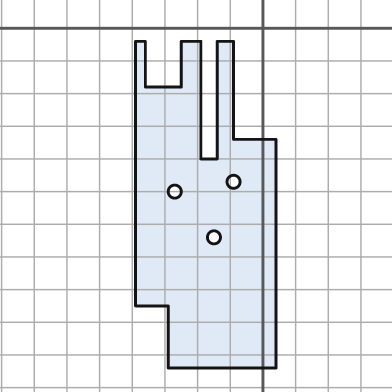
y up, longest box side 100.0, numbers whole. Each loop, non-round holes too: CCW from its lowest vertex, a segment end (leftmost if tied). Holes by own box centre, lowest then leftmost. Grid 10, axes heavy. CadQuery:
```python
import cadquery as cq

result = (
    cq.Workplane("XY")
    .moveTo(-29.0, -104.0)
    .lineTo(4.0, -104.0)
    .lineTo(4.0, -34.0)
    .lineTo(-9.0, -34.0)
    .lineTo(-9.0, -4.0)
    .lineTo(-14.0, -4.0)
    .lineTo(-14.0, -40.0)
    .lineTo(-19.0, -40.0)
    .lineTo(-19.0, -4.0)
    .lineTo(-25.0, -4.0)
    .lineTo(-25.0, -18.0)
    .lineTo(-36.0, -18.0)
    .lineTo(-36.0, -4.0)
    .lineTo(-39.0, -4.0)
    .lineTo(-39.0, -85.0)
    .lineTo(-29.0, -85.0)
    .close()
    .moveTo(-15.0, -64.0)
    .circle(2.0)
    .moveTo(-27.0, -50.0)
    .circle(2.0)
    .moveTo(-9.0, -47.0)
    .circle(2.0)
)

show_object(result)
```